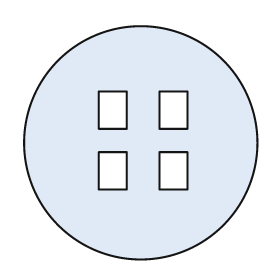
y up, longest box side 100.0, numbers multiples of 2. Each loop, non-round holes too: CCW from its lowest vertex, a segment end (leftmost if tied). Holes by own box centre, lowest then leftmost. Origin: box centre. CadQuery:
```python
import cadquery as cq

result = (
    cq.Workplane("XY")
    .moveTo(0.0, 0.0)
    .circle(50.0)
    .moveTo(-18.0, -20.0)
    .lineTo(-6.0, -20.0)
    .lineTo(-6.0, -4.0)
    .lineTo(-18.0, -4.0)
    .close()
    .moveTo(8.0, -20.0)
    .lineTo(20.0, -20.0)
    .lineTo(20.0, -4.0)
    .lineTo(8.0, -4.0)
    .close()
    .moveTo(-18.0, 6.0)
    .lineTo(-6.0, 6.0)
    .lineTo(-6.0, 22.0)
    .lineTo(-18.0, 22.0)
    .close()
    .moveTo(8.0, 6.0)
    .lineTo(20.0, 6.0)
    .lineTo(20.0, 22.0)
    .lineTo(8.0, 22.0)
    .close()
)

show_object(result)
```